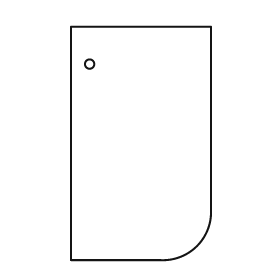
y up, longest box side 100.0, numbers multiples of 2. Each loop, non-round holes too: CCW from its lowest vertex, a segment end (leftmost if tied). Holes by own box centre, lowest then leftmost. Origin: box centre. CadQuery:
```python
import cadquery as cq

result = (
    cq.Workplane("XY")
    .moveTo(-30.0, -50.0)
    .lineTo(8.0, -50.0)
    .threePointArc((24.0, -44.0), (30.0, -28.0))
    .lineTo(30.0, 50.0)
    .lineTo(-30.0, 50.0)
    .close()
    .moveTo(-22.0, 34.0)
    .circle(2.0)
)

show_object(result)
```